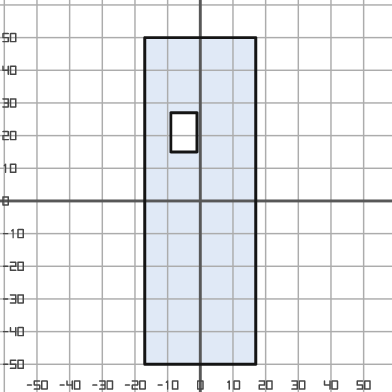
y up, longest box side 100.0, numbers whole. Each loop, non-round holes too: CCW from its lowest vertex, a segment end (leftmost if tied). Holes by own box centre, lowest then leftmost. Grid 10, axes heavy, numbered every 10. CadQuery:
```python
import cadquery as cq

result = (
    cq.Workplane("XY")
    .moveTo(-17.0, -50.0)
    .lineTo(17.0, -50.0)
    .lineTo(17.0, 50.0)
    .lineTo(-17.0, 50.0)
    .close()
    .moveTo(-9.0, 15.0)
    .lineTo(-1.0, 15.0)
    .lineTo(-1.0, 27.0)
    .lineTo(-9.0, 27.0)
    .close()
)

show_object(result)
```